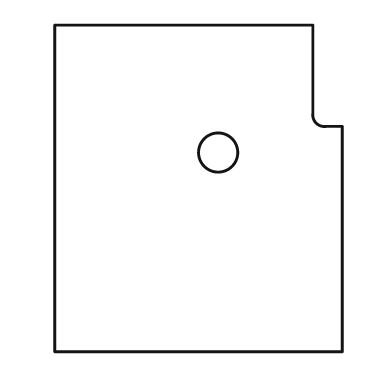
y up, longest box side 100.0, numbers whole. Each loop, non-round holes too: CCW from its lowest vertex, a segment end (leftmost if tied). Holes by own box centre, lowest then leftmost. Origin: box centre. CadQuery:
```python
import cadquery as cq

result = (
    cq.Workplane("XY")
    .moveTo(-44.0, -50.0)
    .lineTo(44.0, -50.0)
    .lineTo(44.0, 19.0)
    .lineTo(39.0, 19.0)
    .threePointArc((36.0, 20.0), (35.0, 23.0))
    .lineTo(35.0, 50.0)
    .lineTo(-44.0, 50.0)
    .close()
    .moveTo(6.0, 11.0)
    .circle(6.0)
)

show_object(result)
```